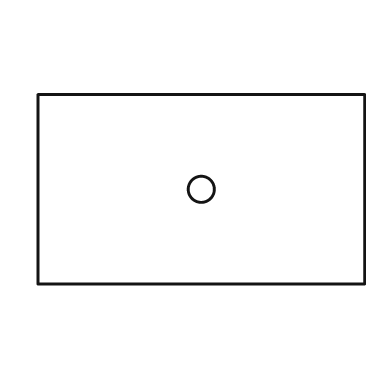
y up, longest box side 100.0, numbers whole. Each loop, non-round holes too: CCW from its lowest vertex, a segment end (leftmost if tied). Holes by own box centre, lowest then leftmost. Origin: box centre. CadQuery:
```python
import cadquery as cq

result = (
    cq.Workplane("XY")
    .moveTo(-50.0, -29.0)
    .lineTo(50.0, -29.0)
    .lineTo(50.0, 29.0)
    .lineTo(-50.0, 29.0)
    .close()
    .moveTo(0.0, 0.0)
    .circle(4.0)
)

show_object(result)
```